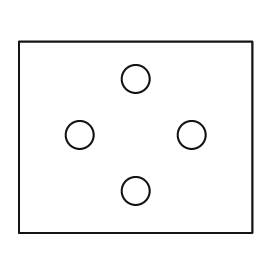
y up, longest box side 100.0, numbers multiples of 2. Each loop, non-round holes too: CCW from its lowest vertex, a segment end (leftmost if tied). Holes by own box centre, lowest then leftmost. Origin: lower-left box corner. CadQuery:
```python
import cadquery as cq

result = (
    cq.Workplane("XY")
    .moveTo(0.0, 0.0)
    .lineTo(100.0, 0.0)
    .lineTo(100.0, 82.0)
    .lineTo(0.0, 82.0)
    .close()
    .moveTo(50.0, 18.0)
    .circle(6.0)
    .moveTo(26.0, 42.0)
    .circle(6.0)
    .moveTo(74.0, 42.0)
    .circle(6.0)
    .moveTo(50.0, 66.0)
    .circle(6.0)
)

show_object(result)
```